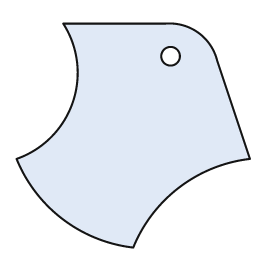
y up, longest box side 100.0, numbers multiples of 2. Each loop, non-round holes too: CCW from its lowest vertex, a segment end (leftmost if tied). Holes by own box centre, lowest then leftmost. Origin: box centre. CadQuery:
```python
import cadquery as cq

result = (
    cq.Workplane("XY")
    .moveTo(0.0, -48.0)
    .threePointArc((20.0, -22.0), (50.0, -10.0))
    .lineTo(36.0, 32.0)
    .threePointArc((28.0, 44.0), (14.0, 48.0))
    .lineTo(-30.0, 48.0)
    .threePointArc((-26.0, 14.0), (-50.0, -10.0))
    .threePointArc((-30.0, -36.0), (0.0, -48.0))
    .close()
    .moveTo(16.0, 34.0)
    .circle(4.0)
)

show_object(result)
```